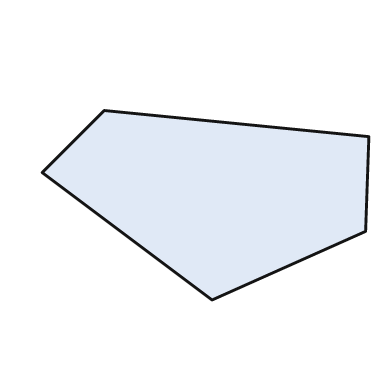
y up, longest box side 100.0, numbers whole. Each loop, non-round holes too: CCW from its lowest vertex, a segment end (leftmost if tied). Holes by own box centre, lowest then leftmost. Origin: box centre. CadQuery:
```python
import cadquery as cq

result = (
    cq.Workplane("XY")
    .moveTo(2.0, -29.0)
    .lineTo(49.0, -8.0)
    .lineTo(50.0, 21.0)
    .lineTo(-31.0, 29.0)
    .lineTo(-50.0, 10.0)
    .close()
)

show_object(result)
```